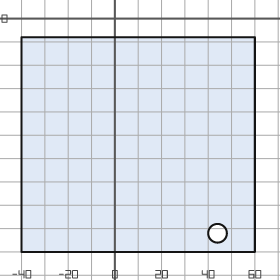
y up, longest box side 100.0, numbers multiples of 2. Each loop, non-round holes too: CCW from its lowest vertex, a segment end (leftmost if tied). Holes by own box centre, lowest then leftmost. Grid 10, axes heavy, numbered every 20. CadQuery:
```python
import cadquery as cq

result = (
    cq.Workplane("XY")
    .moveTo(-40.0, -100.0)
    .lineTo(60.0, -100.0)
    .lineTo(60.0, -8.0)
    .lineTo(-40.0, -8.0)
    .close()
    .moveTo(44.0, -92.0)
    .circle(4.0)
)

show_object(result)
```